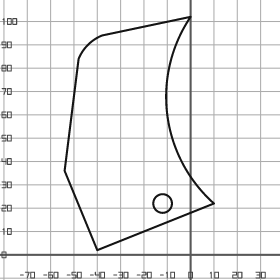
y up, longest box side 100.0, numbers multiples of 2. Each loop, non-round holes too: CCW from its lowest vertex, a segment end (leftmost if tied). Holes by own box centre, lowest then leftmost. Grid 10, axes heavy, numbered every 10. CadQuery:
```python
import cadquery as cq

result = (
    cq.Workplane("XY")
    .moveTo(-40.0, 2.0)
    .lineTo(10.0, 22.0)
    .threePointArc((-10.0, 60.0), (0.0, 102.0))
    .lineTo(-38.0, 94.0)
    .threePointArc((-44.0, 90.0), (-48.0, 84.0))
    .lineTo(-54.0, 36.0)
    .close()
    .moveTo(-12.0, 22.0)
    .circle(4.0)
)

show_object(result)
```